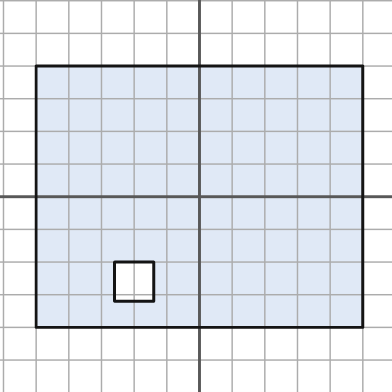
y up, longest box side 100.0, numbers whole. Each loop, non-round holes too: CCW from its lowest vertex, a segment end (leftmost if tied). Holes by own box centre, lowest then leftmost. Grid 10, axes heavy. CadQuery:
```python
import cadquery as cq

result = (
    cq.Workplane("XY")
    .moveTo(-50.0, -40.0)
    .lineTo(50.0, -40.0)
    .lineTo(50.0, 40.0)
    .lineTo(-50.0, 40.0)
    .close()
    .moveTo(-26.0, -32.0)
    .lineTo(-14.0, -32.0)
    .lineTo(-14.0, -20.0)
    .lineTo(-26.0, -20.0)
    .close()
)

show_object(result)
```